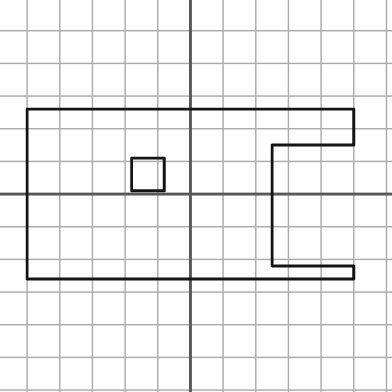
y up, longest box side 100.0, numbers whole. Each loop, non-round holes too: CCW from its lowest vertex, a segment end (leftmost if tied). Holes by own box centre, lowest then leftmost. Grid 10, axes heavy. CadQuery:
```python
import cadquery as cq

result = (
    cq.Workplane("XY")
    .moveTo(-50.0, -26.0)
    .lineTo(50.0, -26.0)
    .lineTo(50.0, -22.0)
    .lineTo(25.0, -22.0)
    .lineTo(25.0, 15.0)
    .lineTo(50.0, 15.0)
    .lineTo(50.0, 26.0)
    .lineTo(-50.0, 26.0)
    .close()
    .moveTo(-18.0, 1.0)
    .lineTo(-8.0, 1.0)
    .lineTo(-8.0, 11.0)
    .lineTo(-18.0, 11.0)
    .close()
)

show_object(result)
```